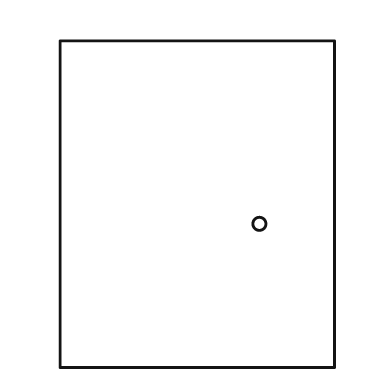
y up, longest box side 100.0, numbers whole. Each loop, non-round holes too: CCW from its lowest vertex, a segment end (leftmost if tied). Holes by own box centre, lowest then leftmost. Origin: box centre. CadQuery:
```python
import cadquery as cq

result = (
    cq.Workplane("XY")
    .moveTo(-42.0, -50.0)
    .lineTo(42.0, -50.0)
    .lineTo(42.0, 50.0)
    .lineTo(-42.0, 50.0)
    .close()
    .moveTo(19.0, -6.0)
    .circle(2.0)
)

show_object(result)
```